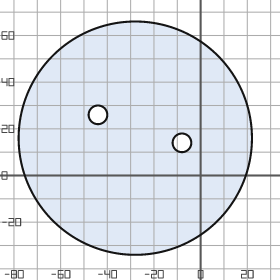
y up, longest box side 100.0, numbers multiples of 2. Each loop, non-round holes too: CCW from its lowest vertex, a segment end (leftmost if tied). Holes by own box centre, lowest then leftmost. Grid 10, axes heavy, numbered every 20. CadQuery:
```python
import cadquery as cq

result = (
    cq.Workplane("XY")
    .moveTo(-28.0, 16.0)
    .circle(50.0)
    .moveTo(-8.0, 14.0)
    .circle(4.0)
    .moveTo(-44.0, 26.0)
    .circle(4.0)
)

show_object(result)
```